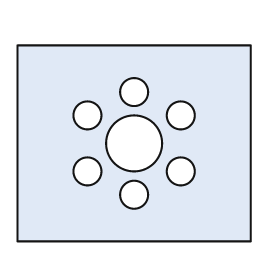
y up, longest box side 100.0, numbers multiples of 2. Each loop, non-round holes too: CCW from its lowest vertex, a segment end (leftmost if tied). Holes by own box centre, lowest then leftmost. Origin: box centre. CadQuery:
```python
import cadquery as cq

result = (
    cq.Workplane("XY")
    .moveTo(-50.0, -42.0)
    .lineTo(50.0, -42.0)
    .lineTo(50.0, 42.0)
    .lineTo(-50.0, 42.0)
    .close()
    .moveTo(0.0, -22.0)
    .circle(6.0)
    .moveTo(-20.0, -12.0)
    .circle(6.0)
    .moveTo(20.0, -12.0)
    .circle(6.0)
    .moveTo(0.0, 0.0)
    .circle(12.0)
    .moveTo(-20.0, 12.0)
    .circle(6.0)
    .moveTo(20.0, 12.0)
    .circle(6.0)
    .moveTo(0.0, 22.0)
    .circle(6.0)
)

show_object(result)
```